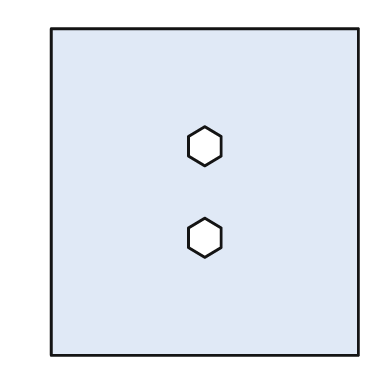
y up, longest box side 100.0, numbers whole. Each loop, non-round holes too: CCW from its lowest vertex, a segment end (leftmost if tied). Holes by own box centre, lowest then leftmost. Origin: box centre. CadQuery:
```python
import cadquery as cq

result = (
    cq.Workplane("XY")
    .moveTo(-47.0, -50.0)
    .lineTo(47.0, -50.0)
    .lineTo(47.0, 50.0)
    .lineTo(-47.0, 50.0)
    .close()
    .moveTo(0.0, -20.0)
    .lineTo(5.0, -17.0)
    .lineTo(5.0, -11.0)
    .lineTo(0.0, -8.0)
    .lineTo(-5.0, -11.0)
    .lineTo(-5.0, -17.0)
    .close()
    .moveTo(0.0, 8.0)
    .lineTo(5.0, 11.0)
    .lineTo(5.0, 17.0)
    .lineTo(0.0, 20.0)
    .lineTo(-5.0, 17.0)
    .lineTo(-5.0, 11.0)
    .close()
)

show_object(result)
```